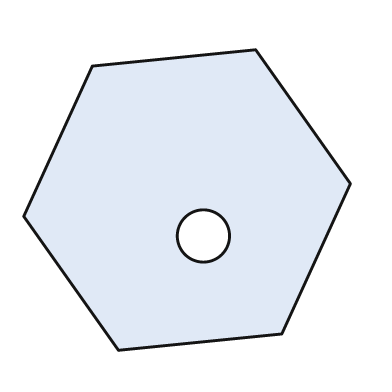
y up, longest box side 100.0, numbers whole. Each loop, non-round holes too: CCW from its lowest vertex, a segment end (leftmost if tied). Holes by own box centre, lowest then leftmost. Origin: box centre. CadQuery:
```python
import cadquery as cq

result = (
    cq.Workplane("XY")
    .moveTo(-21.0, -46.0)
    .lineTo(29.0, -41.0)
    .lineTo(50.0, 5.0)
    .lineTo(21.0, 46.0)
    .lineTo(-29.0, 41.0)
    .lineTo(-50.0, -5.0)
    .close()
    .moveTo(5.0, -11.0)
    .circle(8.0)
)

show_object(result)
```